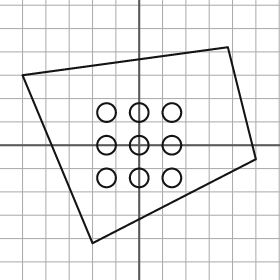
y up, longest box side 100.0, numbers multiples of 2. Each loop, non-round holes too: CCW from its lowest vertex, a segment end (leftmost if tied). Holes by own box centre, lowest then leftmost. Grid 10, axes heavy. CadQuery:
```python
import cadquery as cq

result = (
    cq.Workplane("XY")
    .moveTo(-20.0, -42.0)
    .lineTo(50.0, -6.0)
    .lineTo(38.0, 42.0)
    .lineTo(-50.0, 30.0)
    .close()
    .moveTo(-14.0, -14.0)
    .circle(4.0)
    .moveTo(0.0, -14.0)
    .circle(4.0)
    .moveTo(14.0, -14.0)
    .circle(4.0)
    .moveTo(-14.0, 0.0)
    .circle(4.0)
    .moveTo(0.0, 0.0)
    .circle(4.0)
    .moveTo(14.0, 0.0)
    .circle(4.0)
    .moveTo(-14.0, 14.0)
    .circle(4.0)
    .moveTo(0.0, 14.0)
    .circle(4.0)
    .moveTo(14.0, 14.0)
    .circle(4.0)
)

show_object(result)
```